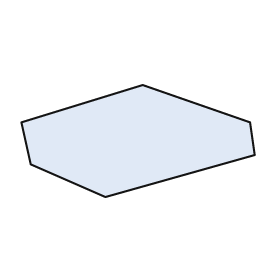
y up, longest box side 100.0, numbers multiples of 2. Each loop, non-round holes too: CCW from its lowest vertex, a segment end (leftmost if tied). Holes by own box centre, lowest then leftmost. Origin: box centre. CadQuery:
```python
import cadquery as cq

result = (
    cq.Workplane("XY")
    .moveTo(-14.0, -24.0)
    .lineTo(50.0, -6.0)
    .lineTo(48.0, 8.0)
    .lineTo(2.0, 24.0)
    .lineTo(-50.0, 8.0)
    .lineTo(-46.0, -10.0)
    .close()
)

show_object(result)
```